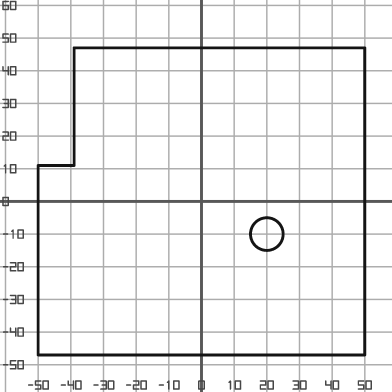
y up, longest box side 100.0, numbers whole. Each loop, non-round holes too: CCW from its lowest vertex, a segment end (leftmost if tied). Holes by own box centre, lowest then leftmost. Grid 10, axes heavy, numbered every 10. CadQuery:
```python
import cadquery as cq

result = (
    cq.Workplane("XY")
    .moveTo(-50.0, -47.0)
    .lineTo(50.0, -47.0)
    .lineTo(50.0, 47.0)
    .lineTo(-39.0, 47.0)
    .lineTo(-39.0, 11.0)
    .lineTo(-50.0, 11.0)
    .close()
    .moveTo(20.0, -10.0)
    .circle(5.0)
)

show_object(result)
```